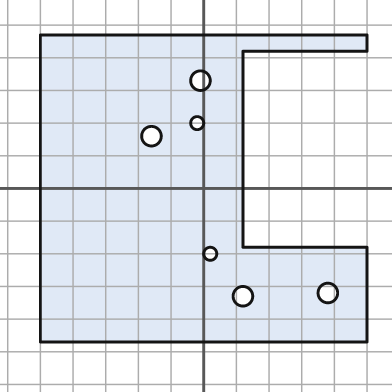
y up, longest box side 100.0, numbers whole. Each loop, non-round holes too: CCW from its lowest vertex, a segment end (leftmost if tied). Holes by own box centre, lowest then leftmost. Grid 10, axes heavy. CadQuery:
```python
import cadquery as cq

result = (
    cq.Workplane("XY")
    .moveTo(-50.0, -47.0)
    .lineTo(50.0, -47.0)
    .lineTo(50.0, -18.0)
    .lineTo(12.0, -18.0)
    .lineTo(12.0, 42.0)
    .lineTo(50.0, 42.0)
    .lineTo(50.0, 47.0)
    .lineTo(-50.0, 47.0)
    .close()
    .moveTo(12.0, -33.0)
    .circle(3.0)
    .moveTo(38.0, -32.0)
    .circle(3.0)
    .moveTo(2.0, -20.0)
    .circle(2.0)
    .moveTo(-16.0, 16.0)
    .circle(3.0)
    .moveTo(-2.0, 20.0)
    .circle(2.0)
    .moveTo(-1.0, 33.0)
    .circle(3.0)
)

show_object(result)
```